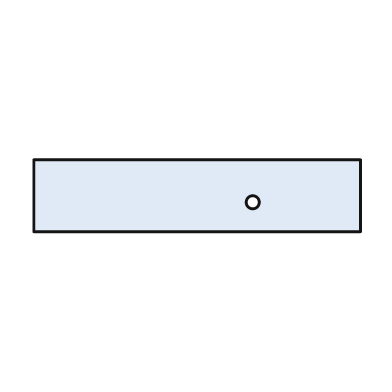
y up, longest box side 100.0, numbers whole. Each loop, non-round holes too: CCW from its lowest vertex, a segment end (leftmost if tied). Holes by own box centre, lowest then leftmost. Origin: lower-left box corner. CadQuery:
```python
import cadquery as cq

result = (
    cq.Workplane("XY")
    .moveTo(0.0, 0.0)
    .lineTo(100.0, 0.0)
    .lineTo(100.0, 22.0)
    .lineTo(0.0, 22.0)
    .close()
    .moveTo(67.0, 9.0)
    .circle(2.0)
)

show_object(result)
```